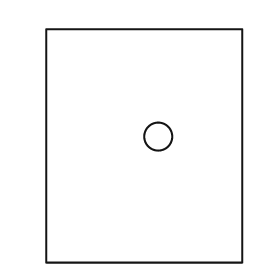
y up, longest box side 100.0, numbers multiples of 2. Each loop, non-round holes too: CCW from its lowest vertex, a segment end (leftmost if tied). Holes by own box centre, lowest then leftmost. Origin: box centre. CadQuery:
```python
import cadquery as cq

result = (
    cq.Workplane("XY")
    .moveTo(-42.0, -50.0)
    .lineTo(42.0, -50.0)
    .lineTo(42.0, 50.0)
    .lineTo(-42.0, 50.0)
    .close()
    .moveTo(6.0, 4.0)
    .circle(6.0)
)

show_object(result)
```